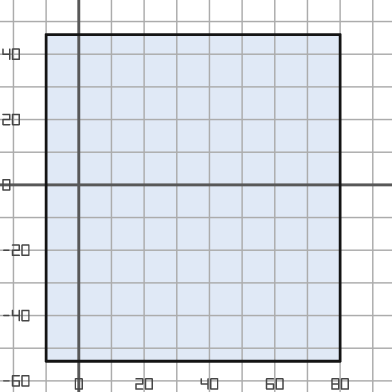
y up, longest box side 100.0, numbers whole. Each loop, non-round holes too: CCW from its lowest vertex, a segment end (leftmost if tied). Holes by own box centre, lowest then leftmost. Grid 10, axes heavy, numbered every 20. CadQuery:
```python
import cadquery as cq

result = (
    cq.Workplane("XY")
    .moveTo(-10.0, -54.0)
    .lineTo(80.0, -54.0)
    .lineTo(80.0, 46.0)
    .lineTo(-10.0, 46.0)
    .close()
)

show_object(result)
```